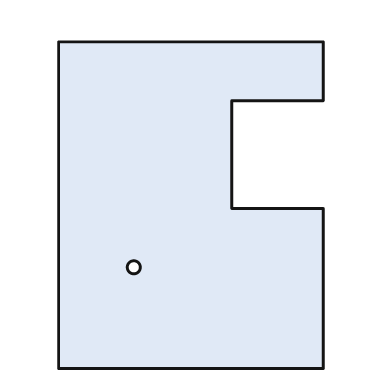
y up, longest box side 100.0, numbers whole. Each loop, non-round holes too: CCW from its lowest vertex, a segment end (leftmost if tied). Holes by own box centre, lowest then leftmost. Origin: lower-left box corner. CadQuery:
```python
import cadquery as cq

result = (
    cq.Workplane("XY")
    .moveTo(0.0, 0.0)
    .lineTo(81.0, 0.0)
    .lineTo(81.0, 49.0)
    .lineTo(53.0, 49.0)
    .lineTo(53.0, 82.0)
    .lineTo(81.0, 82.0)
    .lineTo(81.0, 100.0)
    .lineTo(0.0, 100.0)
    .close()
    .moveTo(23.0, 31.0)
    .circle(2.0)
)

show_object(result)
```